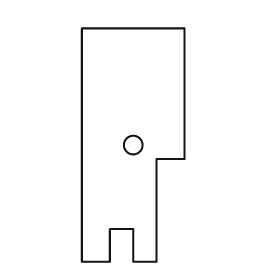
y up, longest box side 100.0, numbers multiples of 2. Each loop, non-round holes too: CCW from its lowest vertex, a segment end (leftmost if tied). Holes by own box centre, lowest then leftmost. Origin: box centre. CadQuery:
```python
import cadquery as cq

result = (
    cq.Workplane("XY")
    .moveTo(-22.0, -50.0)
    .lineTo(-10.0, -50.0)
    .lineTo(-10.0, -36.0)
    .lineTo(0.0, -36.0)
    .lineTo(0.0, -50.0)
    .lineTo(10.0, -50.0)
    .lineTo(10.0, -6.0)
    .lineTo(22.0, -6.0)
    .lineTo(22.0, 50.0)
    .lineTo(-22.0, 50.0)
    .close()
    .moveTo(0.0, 0.0)
    .circle(4.0)
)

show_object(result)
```